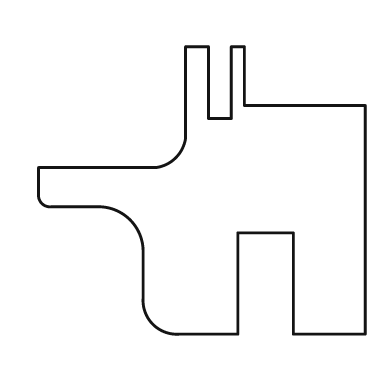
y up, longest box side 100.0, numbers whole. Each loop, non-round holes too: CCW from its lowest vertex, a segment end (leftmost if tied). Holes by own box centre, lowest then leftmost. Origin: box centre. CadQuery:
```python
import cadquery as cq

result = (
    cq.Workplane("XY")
    .moveTo(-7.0, -44.0)
    .lineTo(11.0, -44.0)
    .lineTo(11.0, -13.0)
    .lineTo(28.0, -13.0)
    .lineTo(28.0, -44.0)
    .lineTo(50.0, -44.0)
    .lineTo(50.0, 26.0)
    .lineTo(13.0, 26.0)
    .lineTo(13.0, 44.0)
    .lineTo(9.0, 44.0)
    .lineTo(9.0, 22.0)
    .lineTo(2.0, 22.0)
    .lineTo(2.0, 44.0)
    .lineTo(-5.0, 44.0)
    .lineTo(-5.0, 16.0)
    .threePointArc((-8.0, 10.0), (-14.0, 7.0))
    .lineTo(-50.0, 7.0)
    .lineTo(-50.0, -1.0)
    .threePointArc((-49.0, -4.0), (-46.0, -5.0))
    .lineTo(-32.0, -5.0)
    .threePointArc((-22.0, -9.0), (-18.0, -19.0))
    .lineTo(-18.0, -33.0)
    .threePointArc((-15.0, -41.0), (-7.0, -44.0))
    .close()
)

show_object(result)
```